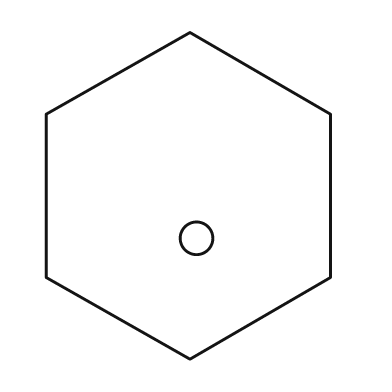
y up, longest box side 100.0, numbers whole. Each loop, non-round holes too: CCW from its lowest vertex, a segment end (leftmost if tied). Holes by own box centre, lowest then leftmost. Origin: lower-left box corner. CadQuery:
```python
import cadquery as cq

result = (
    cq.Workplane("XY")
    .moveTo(44.0, 0.0)
    .lineTo(87.0, 25.0)
    .lineTo(87.0, 75.0)
    .lineTo(44.0, 100.0)
    .lineTo(0.0, 75.0)
    .lineTo(0.0, 25.0)
    .close()
    .moveTo(46.0, 37.0)
    .circle(5.0)
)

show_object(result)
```